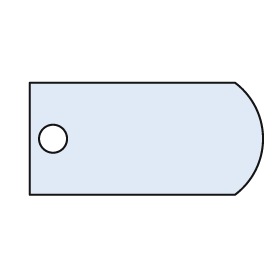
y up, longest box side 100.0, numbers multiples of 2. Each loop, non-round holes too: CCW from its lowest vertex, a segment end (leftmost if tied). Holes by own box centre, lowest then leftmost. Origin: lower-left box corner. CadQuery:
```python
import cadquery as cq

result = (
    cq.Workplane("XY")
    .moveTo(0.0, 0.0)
    .lineTo(88.0, 0.0)
    .threePointArc((100.0, 24.0), (88.0, 48.0))
    .lineTo(0.0, 48.0)
    .close()
    .moveTo(10.0, 24.0)
    .circle(6.0)
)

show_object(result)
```